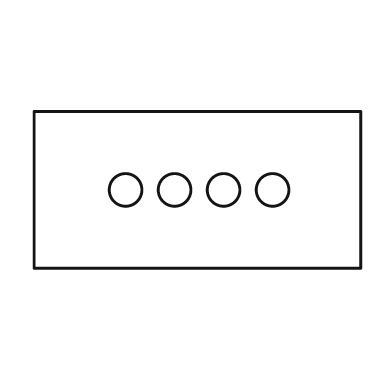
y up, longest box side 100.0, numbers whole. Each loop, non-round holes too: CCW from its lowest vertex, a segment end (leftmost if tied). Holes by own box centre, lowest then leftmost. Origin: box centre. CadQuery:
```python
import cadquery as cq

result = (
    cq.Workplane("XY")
    .moveTo(-50.0, -24.0)
    .lineTo(50.0, -24.0)
    .lineTo(50.0, 24.0)
    .lineTo(-50.0, 24.0)
    .close()
    .moveTo(-22.0, 0.0)
    .circle(5.0)
    .moveTo(-7.0, 0.0)
    .circle(5.0)
    .moveTo(8.0, 0.0)
    .circle(5.0)
    .moveTo(23.0, 0.0)
    .circle(5.0)
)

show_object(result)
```